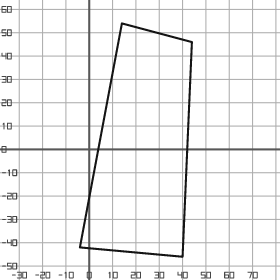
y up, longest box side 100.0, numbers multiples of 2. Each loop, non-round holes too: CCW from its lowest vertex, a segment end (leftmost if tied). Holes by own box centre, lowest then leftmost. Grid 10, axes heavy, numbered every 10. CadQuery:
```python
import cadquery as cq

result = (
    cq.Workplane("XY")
    .moveTo(40.0, -46.0)
    .lineTo(44.0, 46.0)
    .lineTo(14.0, 54.0)
    .lineTo(-4.0, -42.0)
    .close()
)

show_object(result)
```